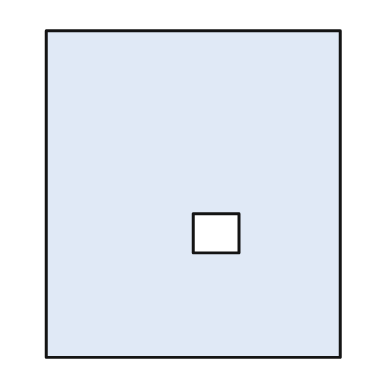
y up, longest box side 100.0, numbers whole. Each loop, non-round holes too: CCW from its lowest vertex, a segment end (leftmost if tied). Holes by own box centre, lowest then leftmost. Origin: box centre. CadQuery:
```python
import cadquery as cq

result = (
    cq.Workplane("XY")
    .moveTo(-45.0, -50.0)
    .lineTo(45.0, -50.0)
    .lineTo(45.0, 50.0)
    .lineTo(-45.0, 50.0)
    .close()
    .moveTo(0.0, -18.0)
    .lineTo(14.0, -18.0)
    .lineTo(14.0, -6.0)
    .lineTo(0.0, -6.0)
    .close()
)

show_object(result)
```